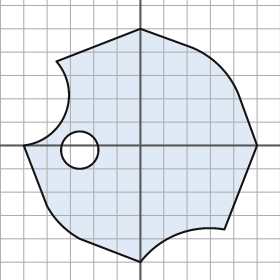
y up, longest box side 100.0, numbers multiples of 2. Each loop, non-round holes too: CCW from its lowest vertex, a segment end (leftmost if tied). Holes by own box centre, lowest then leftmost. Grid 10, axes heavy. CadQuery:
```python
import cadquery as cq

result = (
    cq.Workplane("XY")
    .moveTo(0.0, -50.0)
    .threePointArc((16.0, -38.0), (36.0, -36.0))
    .lineTo(50.0, 0.0)
    .lineTo(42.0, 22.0)
    .threePointArc((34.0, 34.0), (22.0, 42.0))
    .lineTo(0.0, 50.0)
    .lineTo(-36.0, 36.0)
    .threePointArc((-32.0, 14.0), (-50.0, 0.0))
    .lineTo(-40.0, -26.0)
    .threePointArc((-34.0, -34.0), (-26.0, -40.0))
    .close()
    .moveTo(-26.0, -2.0)
    .circle(8.0)
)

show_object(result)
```